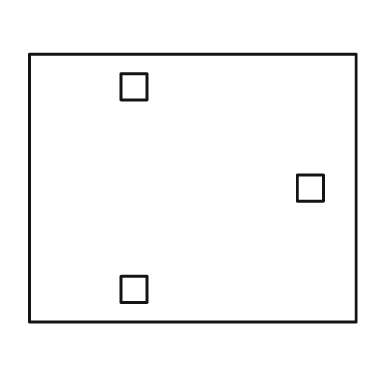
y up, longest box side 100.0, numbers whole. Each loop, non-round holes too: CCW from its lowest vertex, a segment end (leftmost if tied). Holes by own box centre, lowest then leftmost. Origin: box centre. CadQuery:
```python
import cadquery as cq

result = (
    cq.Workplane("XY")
    .moveTo(-50.0, -41.0)
    .lineTo(50.0, -41.0)
    .lineTo(50.0, 41.0)
    .lineTo(-50.0, 41.0)
    .close()
    .moveTo(-22.0, -35.0)
    .lineTo(-14.0, -35.0)
    .lineTo(-14.0, -27.0)
    .lineTo(-22.0, -27.0)
    .close()
    .moveTo(32.0, -4.0)
    .lineTo(40.0, -4.0)
    .lineTo(40.0, 4.0)
    .lineTo(32.0, 4.0)
    .close()
    .moveTo(-22.0, 27.0)
    .lineTo(-14.0, 27.0)
    .lineTo(-14.0, 35.0)
    .lineTo(-22.0, 35.0)
    .close()
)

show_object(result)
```